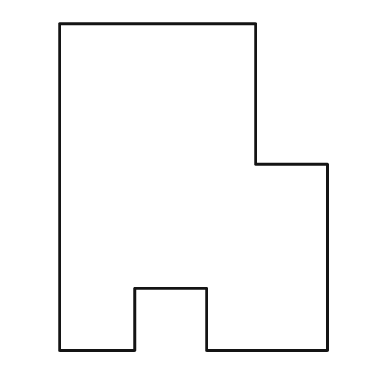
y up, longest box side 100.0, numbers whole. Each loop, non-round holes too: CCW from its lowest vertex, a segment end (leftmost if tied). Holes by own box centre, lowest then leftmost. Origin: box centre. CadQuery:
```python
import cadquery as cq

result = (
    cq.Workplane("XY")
    .moveTo(-41.0, -50.0)
    .lineTo(-18.0, -50.0)
    .lineTo(-18.0, -31.0)
    .lineTo(4.0, -31.0)
    .lineTo(4.0, -50.0)
    .lineTo(41.0, -50.0)
    .lineTo(41.0, 7.0)
    .lineTo(19.0, 7.0)
    .lineTo(19.0, 50.0)
    .lineTo(-41.0, 50.0)
    .close()
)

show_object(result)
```